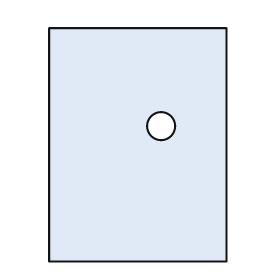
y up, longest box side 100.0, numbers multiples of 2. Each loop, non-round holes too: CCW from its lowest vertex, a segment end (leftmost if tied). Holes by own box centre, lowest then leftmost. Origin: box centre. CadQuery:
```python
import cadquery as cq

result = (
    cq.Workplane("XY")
    .moveTo(-38.0, -50.0)
    .lineTo(38.0, -50.0)
    .lineTo(38.0, 50.0)
    .lineTo(-38.0, 50.0)
    .close()
    .moveTo(10.0, 8.0)
    .circle(6.0)
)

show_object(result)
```